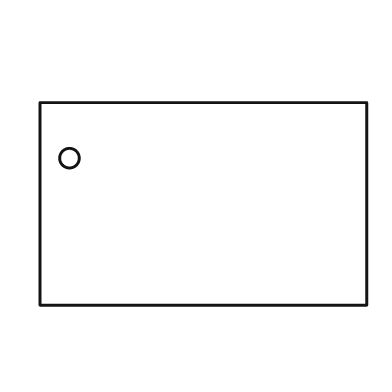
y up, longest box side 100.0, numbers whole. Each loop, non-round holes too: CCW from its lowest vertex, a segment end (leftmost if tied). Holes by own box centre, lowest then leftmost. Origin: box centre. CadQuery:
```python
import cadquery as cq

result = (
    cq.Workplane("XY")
    .moveTo(-50.0, -31.0)
    .lineTo(50.0, -31.0)
    .lineTo(50.0, 31.0)
    .lineTo(-50.0, 31.0)
    .close()
    .moveTo(-41.0, 14.0)
    .circle(3.0)
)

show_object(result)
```